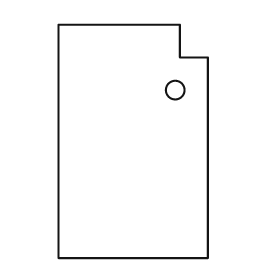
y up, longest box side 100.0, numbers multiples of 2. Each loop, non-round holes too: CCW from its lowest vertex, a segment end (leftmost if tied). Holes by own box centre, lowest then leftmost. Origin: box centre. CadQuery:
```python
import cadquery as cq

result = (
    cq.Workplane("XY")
    .moveTo(-32.0, -50.0)
    .lineTo(32.0, -50.0)
    .lineTo(32.0, 36.0)
    .lineTo(20.0, 36.0)
    .lineTo(20.0, 50.0)
    .lineTo(-32.0, 50.0)
    .close()
    .moveTo(18.0, 22.0)
    .circle(4.0)
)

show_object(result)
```